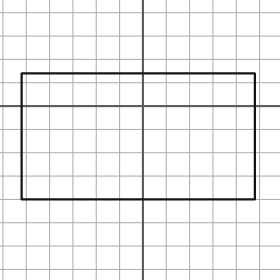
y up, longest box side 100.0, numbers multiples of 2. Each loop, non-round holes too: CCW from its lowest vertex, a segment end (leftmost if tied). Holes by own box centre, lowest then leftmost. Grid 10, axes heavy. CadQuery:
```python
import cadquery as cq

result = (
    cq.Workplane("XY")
    .moveTo(-52.0, -40.0)
    .lineTo(48.0, -40.0)
    .lineTo(48.0, 14.0)
    .lineTo(-52.0, 14.0)
    .close()
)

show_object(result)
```